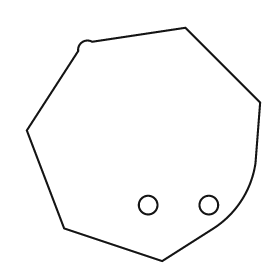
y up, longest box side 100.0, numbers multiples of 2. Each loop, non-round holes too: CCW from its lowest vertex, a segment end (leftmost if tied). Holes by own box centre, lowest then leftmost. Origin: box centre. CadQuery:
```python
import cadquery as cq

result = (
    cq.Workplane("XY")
    .moveTo(8.0, -50.0)
    .lineTo(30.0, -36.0)
    .threePointArc((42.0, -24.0), (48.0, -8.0))
    .lineTo(50.0, 18.0)
    .lineTo(18.0, 50.0)
    .lineTo(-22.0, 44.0)
    .threePointArc((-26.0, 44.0), (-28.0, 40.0))
    .lineTo(-50.0, 6.0)
    .lineTo(-34.0, -36.0)
    .close()
    .moveTo(2.0, -26.0)
    .circle(4.0)
    .moveTo(28.0, -26.0)
    .circle(4.0)
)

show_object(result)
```